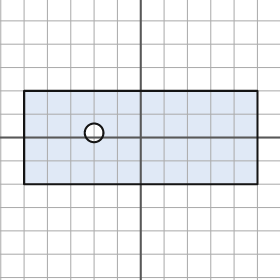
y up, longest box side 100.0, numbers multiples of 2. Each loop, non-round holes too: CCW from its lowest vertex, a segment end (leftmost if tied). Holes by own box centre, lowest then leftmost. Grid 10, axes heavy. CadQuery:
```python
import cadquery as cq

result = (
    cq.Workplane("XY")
    .moveTo(-50.0, -20.0)
    .lineTo(50.0, -20.0)
    .lineTo(50.0, 20.0)
    .lineTo(-50.0, 20.0)
    .close()
    .moveTo(-20.0, 2.0)
    .circle(4.0)
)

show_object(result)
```